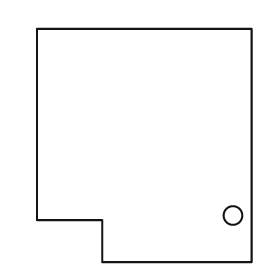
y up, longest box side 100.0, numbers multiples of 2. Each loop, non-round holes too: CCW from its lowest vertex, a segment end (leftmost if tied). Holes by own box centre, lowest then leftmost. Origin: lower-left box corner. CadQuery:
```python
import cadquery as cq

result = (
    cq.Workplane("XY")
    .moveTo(28.0, 0.0)
    .lineTo(92.0, 0.0)
    .lineTo(92.0, 100.0)
    .lineTo(0.0, 100.0)
    .lineTo(0.0, 18.0)
    .lineTo(28.0, 18.0)
    .close()
    .moveTo(84.0, 20.0)
    .circle(4.0)
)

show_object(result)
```